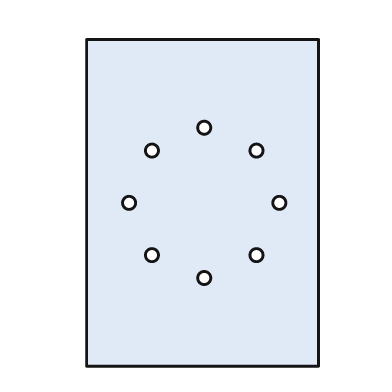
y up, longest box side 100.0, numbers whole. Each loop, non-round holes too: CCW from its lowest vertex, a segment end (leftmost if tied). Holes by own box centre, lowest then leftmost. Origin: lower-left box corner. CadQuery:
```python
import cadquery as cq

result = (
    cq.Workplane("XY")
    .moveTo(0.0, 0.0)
    .lineTo(71.0, 0.0)
    .lineTo(71.0, 100.0)
    .lineTo(0.0, 100.0)
    .close()
    .moveTo(36.0, 27.0)
    .circle(2.0)
    .moveTo(20.0, 34.0)
    .circle(2.0)
    .moveTo(52.0, 34.0)
    .circle(2.0)
    .moveTo(13.0, 50.0)
    .circle(2.0)
    .moveTo(59.0, 50.0)
    .circle(2.0)
    .moveTo(20.0, 66.0)
    .circle(2.0)
    .moveTo(52.0, 66.0)
    .circle(2.0)
    .moveTo(36.0, 73.0)
    .circle(2.0)
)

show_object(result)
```